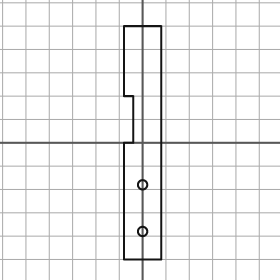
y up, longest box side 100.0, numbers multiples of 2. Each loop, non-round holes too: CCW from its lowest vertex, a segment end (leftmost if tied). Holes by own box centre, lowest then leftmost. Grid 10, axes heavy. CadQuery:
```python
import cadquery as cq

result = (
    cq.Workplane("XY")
    .moveTo(-8.0, -50.0)
    .lineTo(8.0, -50.0)
    .lineTo(8.0, 50.0)
    .lineTo(-8.0, 50.0)
    .lineTo(-8.0, 20.0)
    .lineTo(-4.0, 20.0)
    .lineTo(-4.0, 0.0)
    .lineTo(-8.0, 0.0)
    .close()
    .moveTo(0.0, -38.0)
    .circle(2.0)
    .moveTo(0.0, -18.0)
    .circle(2.0)
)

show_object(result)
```